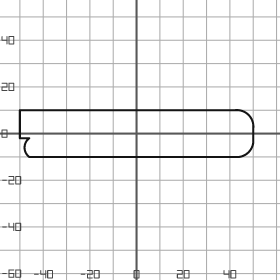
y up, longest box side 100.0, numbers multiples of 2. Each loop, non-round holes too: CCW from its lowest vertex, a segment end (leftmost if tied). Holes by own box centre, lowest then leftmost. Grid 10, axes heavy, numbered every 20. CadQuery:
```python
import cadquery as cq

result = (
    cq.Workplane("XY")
    .moveTo(-46.0, -10.0)
    .lineTo(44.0, -10.0)
    .threePointArc((48.0, -8.0), (50.0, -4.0))
    .lineTo(50.0, 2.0)
    .threePointArc((48.0, 8.0), (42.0, 10.0))
    .lineTo(-50.0, 10.0)
    .lineTo(-50.0, -2.0)
    .lineTo(-46.0, -2.0)
    .threePointArc((-48.0, -6.0), (-46.0, -10.0))
    .close()
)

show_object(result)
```